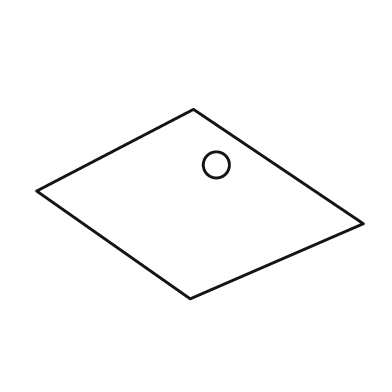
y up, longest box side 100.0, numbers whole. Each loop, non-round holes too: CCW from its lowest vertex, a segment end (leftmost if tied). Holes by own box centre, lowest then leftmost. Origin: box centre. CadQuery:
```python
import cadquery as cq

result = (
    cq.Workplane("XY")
    .moveTo(-3.0, -29.0)
    .lineTo(50.0, -6.0)
    .lineTo(-2.0, 29.0)
    .lineTo(-50.0, 4.0)
    .close()
    .moveTo(5.0, 12.0)
    .circle(4.0)
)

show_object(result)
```